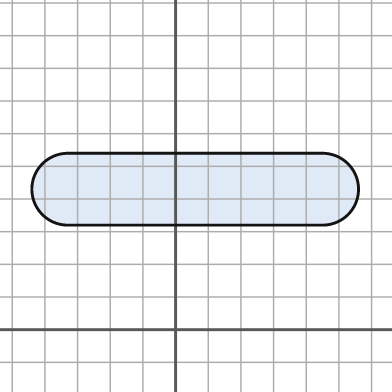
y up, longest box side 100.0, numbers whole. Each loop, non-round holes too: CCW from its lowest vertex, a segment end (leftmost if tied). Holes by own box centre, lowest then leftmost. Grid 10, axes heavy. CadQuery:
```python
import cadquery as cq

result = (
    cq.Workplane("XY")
    .moveTo(-33.0, 32.0)
    .lineTo(45.0, 32.0)
    .threePointArc((56.0, 43.0), (45.0, 54.0))
    .lineTo(-33.0, 54.0)
    .threePointArc((-44.0, 43.0), (-33.0, 32.0))
    .close()
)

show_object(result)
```